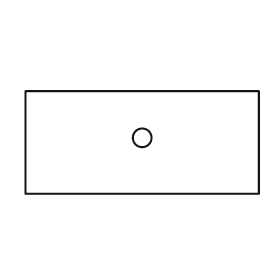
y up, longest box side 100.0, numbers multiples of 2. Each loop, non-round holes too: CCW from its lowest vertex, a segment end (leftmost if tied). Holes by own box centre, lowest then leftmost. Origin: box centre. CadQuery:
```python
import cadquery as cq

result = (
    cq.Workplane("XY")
    .moveTo(-50.0, -22.0)
    .lineTo(50.0, -22.0)
    .lineTo(50.0, 22.0)
    .lineTo(-50.0, 22.0)
    .close()
    .moveTo(0.0, 2.0)
    .circle(4.0)
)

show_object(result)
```